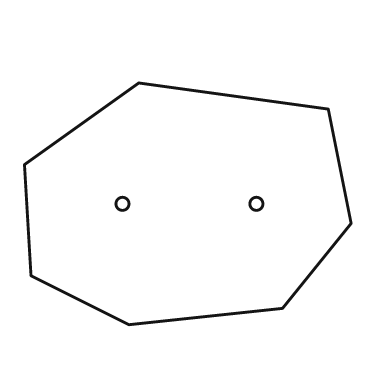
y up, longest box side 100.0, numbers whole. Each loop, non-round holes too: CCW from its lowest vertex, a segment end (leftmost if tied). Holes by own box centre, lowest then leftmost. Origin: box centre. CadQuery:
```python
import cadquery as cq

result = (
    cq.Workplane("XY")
    .moveTo(-18.0, -37.0)
    .lineTo(29.0, -32.0)
    .lineTo(50.0, -6.0)
    .lineTo(43.0, 29.0)
    .lineTo(-15.0, 37.0)
    .lineTo(-50.0, 12.0)
    .lineTo(-48.0, -22.0)
    .close()
    .moveTo(-20.0, 0.0)
    .circle(2.0)
    .moveTo(21.0, 0.0)
    .circle(2.0)
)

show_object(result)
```